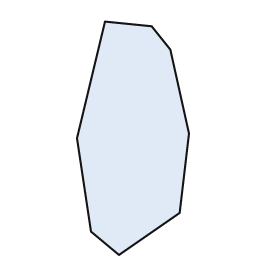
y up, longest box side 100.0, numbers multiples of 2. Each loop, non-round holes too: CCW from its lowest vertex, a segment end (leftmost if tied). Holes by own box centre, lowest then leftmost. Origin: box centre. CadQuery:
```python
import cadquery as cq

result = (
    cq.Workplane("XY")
    .moveTo(-6.0, -50.0)
    .lineTo(20.0, -32.0)
    .lineTo(24.0, 2.0)
    .lineTo(16.0, 38.0)
    .lineTo(8.0, 48.0)
    .lineTo(-12.0, 50.0)
    .lineTo(-24.0, 0.0)
    .lineTo(-18.0, -40.0)
    .close()
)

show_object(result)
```